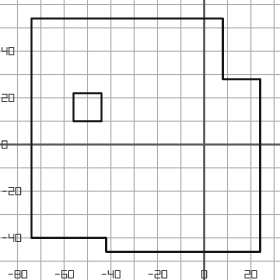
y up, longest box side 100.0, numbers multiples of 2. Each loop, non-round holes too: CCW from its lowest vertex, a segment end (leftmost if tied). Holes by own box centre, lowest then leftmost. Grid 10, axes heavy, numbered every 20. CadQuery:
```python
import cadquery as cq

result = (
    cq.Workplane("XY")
    .moveTo(-42.0, -46.0)
    .lineTo(24.0, -46.0)
    .lineTo(24.0, 28.0)
    .lineTo(8.0, 28.0)
    .lineTo(8.0, 54.0)
    .lineTo(-74.0, 54.0)
    .lineTo(-74.0, -40.0)
    .lineTo(-42.0, -40.0)
    .close()
    .moveTo(-56.0, 10.0)
    .lineTo(-44.0, 10.0)
    .lineTo(-44.0, 22.0)
    .lineTo(-56.0, 22.0)
    .close()
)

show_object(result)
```